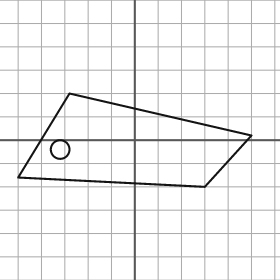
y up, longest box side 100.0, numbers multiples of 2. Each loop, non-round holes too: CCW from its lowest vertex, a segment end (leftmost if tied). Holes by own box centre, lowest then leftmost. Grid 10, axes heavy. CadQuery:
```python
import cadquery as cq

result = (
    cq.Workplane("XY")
    .moveTo(30.0, -20.0)
    .lineTo(50.0, 2.0)
    .lineTo(-28.0, 20.0)
    .lineTo(-50.0, -16.0)
    .close()
    .moveTo(-32.0, -4.0)
    .circle(4.0)
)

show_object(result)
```